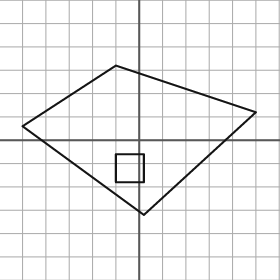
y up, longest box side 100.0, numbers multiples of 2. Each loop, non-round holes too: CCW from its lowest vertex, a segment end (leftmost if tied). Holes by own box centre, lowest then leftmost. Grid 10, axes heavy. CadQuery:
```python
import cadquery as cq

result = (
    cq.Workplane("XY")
    .moveTo(2.0, -32.0)
    .lineTo(50.0, 12.0)
    .lineTo(-10.0, 32.0)
    .lineTo(-50.0, 6.0)
    .close()
    .moveTo(-10.0, -18.0)
    .lineTo(2.0, -18.0)
    .lineTo(2.0, -6.0)
    .lineTo(-10.0, -6.0)
    .close()
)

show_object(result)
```